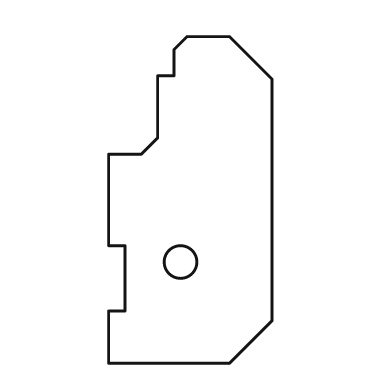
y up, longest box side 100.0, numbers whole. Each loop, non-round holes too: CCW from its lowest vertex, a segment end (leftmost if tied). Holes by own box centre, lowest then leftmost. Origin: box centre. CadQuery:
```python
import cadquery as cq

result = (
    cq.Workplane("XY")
    .moveTo(-25.0, -50.0)
    .lineTo(12.0, -50.0)
    .lineTo(25.0, -37.0)
    .lineTo(25.0, 37.0)
    .lineTo(12.0, 50.0)
    .lineTo(-1.0, 50.0)
    .lineTo(-5.0, 46.0)
    .lineTo(-5.0, 38.0)
    .lineTo(-10.0, 38.0)
    .lineTo(-10.0, 19.0)
    .lineTo(-15.0, 14.0)
    .lineTo(-25.0, 14.0)
    .lineTo(-25.0, -14.0)
    .lineTo(-20.0, -14.0)
    .lineTo(-20.0, -34.0)
    .lineTo(-25.0, -34.0)
    .close()
    .moveTo(-3.0, -19.0)
    .circle(5.0)
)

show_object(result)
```